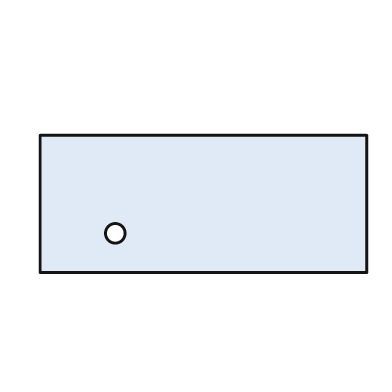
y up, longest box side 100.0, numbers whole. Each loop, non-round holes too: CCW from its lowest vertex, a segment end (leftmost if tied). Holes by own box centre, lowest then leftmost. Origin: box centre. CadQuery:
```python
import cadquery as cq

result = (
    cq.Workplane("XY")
    .moveTo(-50.0, -21.0)
    .lineTo(50.0, -21.0)
    .lineTo(50.0, 21.0)
    .lineTo(-50.0, 21.0)
    .close()
    .moveTo(-27.0, -9.0)
    .circle(3.0)
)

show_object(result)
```